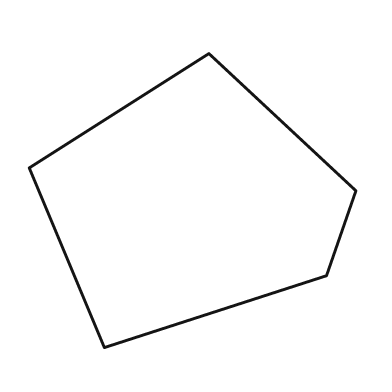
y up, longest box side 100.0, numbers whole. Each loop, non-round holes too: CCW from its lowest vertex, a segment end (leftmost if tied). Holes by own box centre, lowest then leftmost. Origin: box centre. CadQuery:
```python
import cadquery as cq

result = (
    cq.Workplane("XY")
    .moveTo(-27.0, -45.0)
    .lineTo(41.0, -23.0)
    .lineTo(50.0, 3.0)
    .lineTo(5.0, 45.0)
    .lineTo(-50.0, 10.0)
    .close()
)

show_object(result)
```